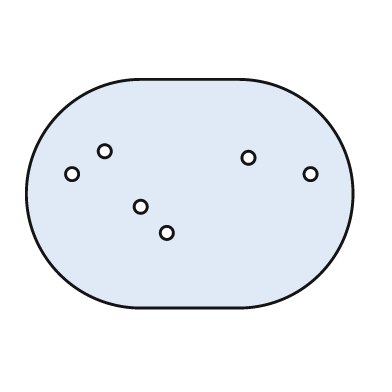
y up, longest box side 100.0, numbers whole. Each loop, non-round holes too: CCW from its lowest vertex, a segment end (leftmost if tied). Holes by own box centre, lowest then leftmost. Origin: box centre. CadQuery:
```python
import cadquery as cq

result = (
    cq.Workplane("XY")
    .moveTo(-15.0, -35.0)
    .lineTo(15.0, -35.0)
    .threePointArc((50.0, 0.0), (15.0, 35.0))
    .lineTo(-15.0, 35.0)
    .threePointArc((-50.0, 0.0), (-15.0, -35.0))
    .close()
    .moveTo(-7.0, -12.0)
    .circle(2.0)
    .moveTo(-15.0, -4.0)
    .circle(2.0)
    .moveTo(-36.0, 6.0)
    .circle(2.0)
    .moveTo(37.0, 6.0)
    .circle(2.0)
    .moveTo(18.0, 11.0)
    .circle(2.0)
    .moveTo(-26.0, 13.0)
    .circle(2.0)
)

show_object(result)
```